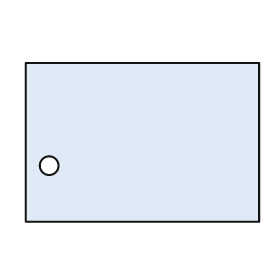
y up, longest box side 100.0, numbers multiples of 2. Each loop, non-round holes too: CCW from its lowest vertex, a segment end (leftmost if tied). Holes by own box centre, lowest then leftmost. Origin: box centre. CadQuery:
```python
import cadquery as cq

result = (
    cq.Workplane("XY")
    .moveTo(-50.0, -34.0)
    .lineTo(50.0, -34.0)
    .lineTo(50.0, 34.0)
    .lineTo(-50.0, 34.0)
    .close()
    .moveTo(-40.0, -10.0)
    .circle(4.0)
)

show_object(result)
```